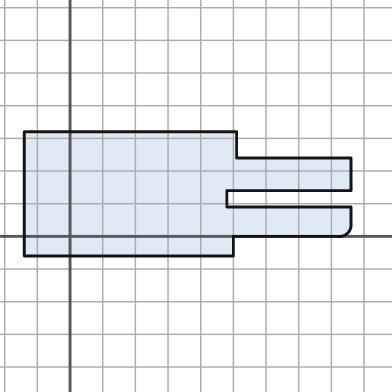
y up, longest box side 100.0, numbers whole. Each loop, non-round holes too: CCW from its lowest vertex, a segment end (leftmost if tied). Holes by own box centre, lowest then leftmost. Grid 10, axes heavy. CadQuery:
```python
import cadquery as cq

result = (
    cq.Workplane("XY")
    .moveTo(-14.0, -6.0)
    .lineTo(50.0, -6.0)
    .lineTo(50.0, 0.0)
    .lineTo(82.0, 0.0)
    .threePointArc((85.0, 1.0), (86.0, 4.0))
    .lineTo(86.0, 9.0)
    .lineTo(48.0, 9.0)
    .lineTo(48.0, 14.0)
    .lineTo(86.0, 14.0)
    .lineTo(86.0, 24.0)
    .lineTo(51.0, 24.0)
    .lineTo(51.0, 32.0)
    .lineTo(-14.0, 32.0)
    .close()
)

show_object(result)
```